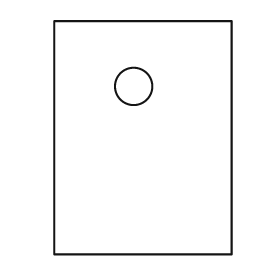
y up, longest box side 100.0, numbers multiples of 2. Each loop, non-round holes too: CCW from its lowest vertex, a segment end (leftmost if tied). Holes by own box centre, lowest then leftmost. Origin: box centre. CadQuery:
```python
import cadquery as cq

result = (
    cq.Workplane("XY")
    .moveTo(-38.0, -50.0)
    .lineTo(38.0, -50.0)
    .lineTo(38.0, 50.0)
    .lineTo(-38.0, 50.0)
    .close()
    .moveTo(-4.0, 22.0)
    .circle(8.0)
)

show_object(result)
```